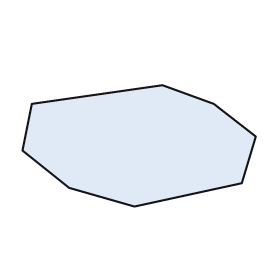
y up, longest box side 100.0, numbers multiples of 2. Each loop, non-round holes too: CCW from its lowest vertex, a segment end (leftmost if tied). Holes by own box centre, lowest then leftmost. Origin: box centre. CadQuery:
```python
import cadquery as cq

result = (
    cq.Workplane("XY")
    .moveTo(-2.0, -26.0)
    .lineTo(44.0, -16.0)
    .lineTo(50.0, 4.0)
    .lineTo(32.0, 18.0)
    .lineTo(10.0, 26.0)
    .lineTo(-46.0, 18.0)
    .lineTo(-50.0, -2.0)
    .lineTo(-30.0, -18.0)
    .close()
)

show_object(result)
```